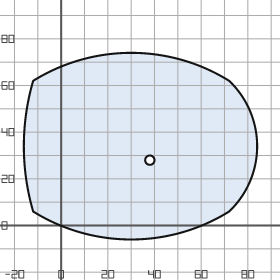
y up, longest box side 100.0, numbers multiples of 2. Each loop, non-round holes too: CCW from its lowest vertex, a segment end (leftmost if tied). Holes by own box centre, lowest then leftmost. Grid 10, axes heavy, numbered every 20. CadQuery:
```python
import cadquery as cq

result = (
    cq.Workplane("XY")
    .moveTo(-12.0, 6.0)
    .threePointArc((30.0, -6.0), (72.0, 6.0))
    .threePointArc((84.0, 34.0), (72.0, 62.0))
    .threePointArc((30.0, 74.0), (-12.0, 62.0))
    .threePointArc((-16.0, 34.0), (-12.0, 6.0))
    .close()
    .moveTo(38.0, 28.0)
    .circle(2.0)
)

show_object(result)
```